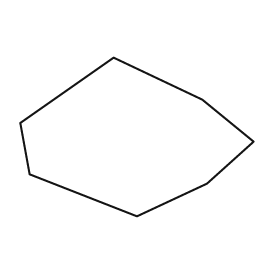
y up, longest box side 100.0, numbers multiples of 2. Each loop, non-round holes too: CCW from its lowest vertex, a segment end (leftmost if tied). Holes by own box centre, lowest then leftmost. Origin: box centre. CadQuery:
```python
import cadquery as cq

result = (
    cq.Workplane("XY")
    .moveTo(0.0, -34.0)
    .lineTo(30.0, -20.0)
    .lineTo(50.0, -2.0)
    .lineTo(28.0, 16.0)
    .lineTo(-10.0, 34.0)
    .lineTo(-50.0, 6.0)
    .lineTo(-46.0, -16.0)
    .close()
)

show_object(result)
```